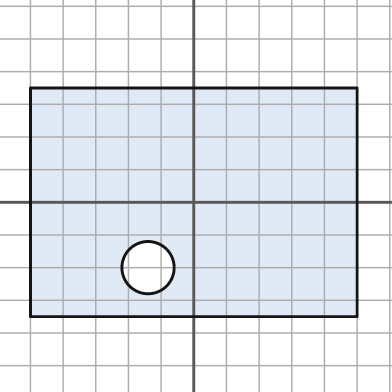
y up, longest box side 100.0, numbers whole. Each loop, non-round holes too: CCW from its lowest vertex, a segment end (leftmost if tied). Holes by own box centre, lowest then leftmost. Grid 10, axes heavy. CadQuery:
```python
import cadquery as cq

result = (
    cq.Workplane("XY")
    .moveTo(-50.0, -35.0)
    .lineTo(50.0, -35.0)
    .lineTo(50.0, 35.0)
    .lineTo(-50.0, 35.0)
    .close()
    .moveTo(-14.0, -20.0)
    .circle(8.0)
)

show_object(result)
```